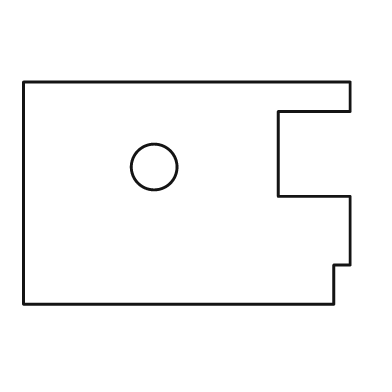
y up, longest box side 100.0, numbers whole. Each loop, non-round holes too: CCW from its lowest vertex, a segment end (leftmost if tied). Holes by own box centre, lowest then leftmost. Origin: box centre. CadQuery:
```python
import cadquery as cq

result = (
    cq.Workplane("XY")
    .moveTo(-50.0, -34.0)
    .lineTo(45.0, -34.0)
    .lineTo(45.0, -22.0)
    .lineTo(50.0, -22.0)
    .lineTo(50.0, -1.0)
    .lineTo(28.0, -1.0)
    .lineTo(28.0, 25.0)
    .lineTo(50.0, 25.0)
    .lineTo(50.0, 34.0)
    .lineTo(-50.0, 34.0)
    .close()
    .moveTo(-10.0, 8.0)
    .circle(7.0)
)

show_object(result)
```